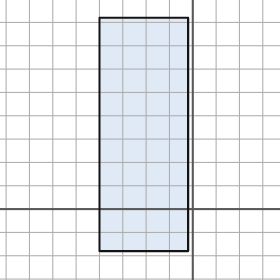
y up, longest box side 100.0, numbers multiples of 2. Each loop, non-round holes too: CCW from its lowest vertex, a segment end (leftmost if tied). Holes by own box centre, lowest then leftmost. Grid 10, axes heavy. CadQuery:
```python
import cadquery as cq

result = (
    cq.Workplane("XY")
    .moveTo(-40.0, -18.0)
    .lineTo(-2.0, -18.0)
    .lineTo(-2.0, 82.0)
    .lineTo(-40.0, 82.0)
    .close()
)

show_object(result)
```